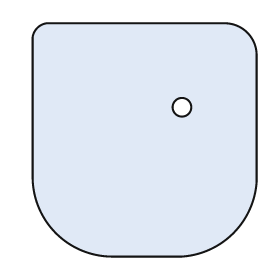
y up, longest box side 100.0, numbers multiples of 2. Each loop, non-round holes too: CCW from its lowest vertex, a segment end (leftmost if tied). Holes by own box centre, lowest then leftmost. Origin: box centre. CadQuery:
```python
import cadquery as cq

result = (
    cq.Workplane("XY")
    .moveTo(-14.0, -50.0)
    .lineTo(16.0, -50.0)
    .threePointArc((38.0, -40.0), (48.0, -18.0))
    .lineTo(48.0, 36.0)
    .threePointArc((44.0, 46.0), (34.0, 50.0))
    .lineTo(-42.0, 50.0)
    .threePointArc((-46.0, 48.0), (-48.0, 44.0))
    .lineTo(-48.0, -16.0)
    .threePointArc((-38.0, -40.0), (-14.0, -50.0))
    .close()
    .moveTo(16.0, 14.0)
    .circle(4.0)
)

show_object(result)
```